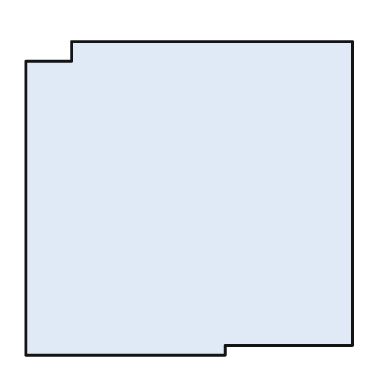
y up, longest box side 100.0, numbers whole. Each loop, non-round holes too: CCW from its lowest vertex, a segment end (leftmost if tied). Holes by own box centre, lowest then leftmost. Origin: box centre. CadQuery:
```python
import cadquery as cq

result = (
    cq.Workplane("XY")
    .moveTo(-50.0, -48.0)
    .lineTo(11.0, -48.0)
    .lineTo(11.0, -45.0)
    .lineTo(50.0, -45.0)
    .lineTo(50.0, 48.0)
    .lineTo(-36.0, 48.0)
    .lineTo(-36.0, 42.0)
    .lineTo(-50.0, 42.0)
    .close()
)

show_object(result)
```